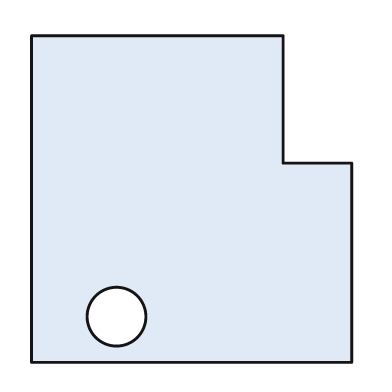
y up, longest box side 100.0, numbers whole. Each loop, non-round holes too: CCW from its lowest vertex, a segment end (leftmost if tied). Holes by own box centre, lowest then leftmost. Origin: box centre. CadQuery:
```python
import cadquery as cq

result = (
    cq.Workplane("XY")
    .moveTo(-49.0, -50.0)
    .lineTo(49.0, -50.0)
    .lineTo(49.0, 11.0)
    .lineTo(28.0, 11.0)
    .lineTo(28.0, 50.0)
    .lineTo(-49.0, 50.0)
    .close()
    .moveTo(-23.0, -36.0)
    .circle(9.0)
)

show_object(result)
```